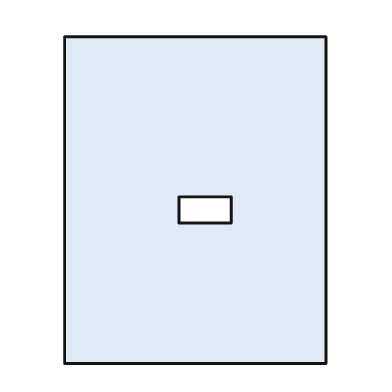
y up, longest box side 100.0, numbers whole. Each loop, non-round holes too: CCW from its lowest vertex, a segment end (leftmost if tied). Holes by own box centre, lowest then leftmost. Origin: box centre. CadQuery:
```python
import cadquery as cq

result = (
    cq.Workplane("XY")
    .moveTo(-40.0, -50.0)
    .lineTo(40.0, -50.0)
    .lineTo(40.0, 50.0)
    .lineTo(-40.0, 50.0)
    .close()
    .moveTo(-5.0, -7.0)
    .lineTo(11.0, -7.0)
    .lineTo(11.0, 1.0)
    .lineTo(-5.0, 1.0)
    .close()
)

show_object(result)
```